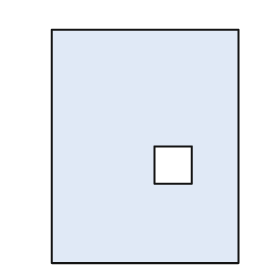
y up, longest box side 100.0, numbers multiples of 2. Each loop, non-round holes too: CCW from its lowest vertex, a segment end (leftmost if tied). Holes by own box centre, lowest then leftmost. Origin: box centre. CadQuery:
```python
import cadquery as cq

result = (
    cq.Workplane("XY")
    .moveTo(-40.0, -50.0)
    .lineTo(40.0, -50.0)
    .lineTo(40.0, 50.0)
    .lineTo(-40.0, 50.0)
    .close()
    .moveTo(4.0, -16.0)
    .lineTo(20.0, -16.0)
    .lineTo(20.0, 0.0)
    .lineTo(4.0, 0.0)
    .close()
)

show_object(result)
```